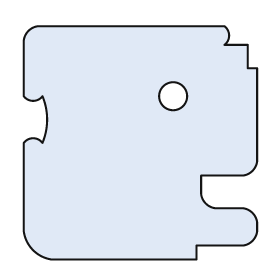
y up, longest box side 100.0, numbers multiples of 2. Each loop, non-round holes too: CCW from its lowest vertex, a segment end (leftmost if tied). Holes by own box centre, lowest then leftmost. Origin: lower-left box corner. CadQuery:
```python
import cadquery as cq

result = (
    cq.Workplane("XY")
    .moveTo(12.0, 0.0)
    .lineTo(74.0, 0.0)
    .lineTo(74.0, 6.0)
    .lineTo(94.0, 6.0)
    .threePointArc((98.0, 8.0), (100.0, 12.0))
    .lineTo(100.0, 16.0)
    .threePointArc((98.0, 20.0), (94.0, 22.0))
    .lineTo(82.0, 22.0)
    .threePointArc((78.0, 24.0), (76.0, 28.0))
    .lineTo(76.0, 36.0)
    .lineTo(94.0, 36.0)
    .threePointArc((98.0, 38.0), (100.0, 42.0))
    .lineTo(100.0, 82.0)
    .lineTo(96.0, 82.0)
    .lineTo(96.0, 92.0)
    .lineTo(86.0, 92.0)
    .threePointArc((88.0, 96.0), (86.0, 100.0))
    .lineTo(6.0, 100.0)
    .threePointArc((2.0, 98.0), (0.0, 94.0))
    .lineTo(0.0, 70.0)
    .threePointArc((4.0, 68.0), (8.0, 70.0))
    .threePointArc((10.0, 60.0), (8.0, 50.0))
    .threePointArc((4.0, 52.0), (0.0, 50.0))
    .lineTo(0.0, 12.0)
    .threePointArc((4.0, 4.0), (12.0, 0.0))
    .close()
    .moveTo(64.0, 70.0)
    .circle(6.0)
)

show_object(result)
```